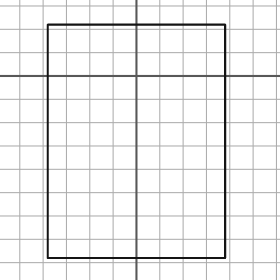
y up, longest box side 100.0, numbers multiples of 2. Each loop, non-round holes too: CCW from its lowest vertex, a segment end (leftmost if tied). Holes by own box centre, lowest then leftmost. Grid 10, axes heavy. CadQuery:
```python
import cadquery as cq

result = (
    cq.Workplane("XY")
    .moveTo(-38.0, -78.0)
    .lineTo(38.0, -78.0)
    .lineTo(38.0, 22.0)
    .lineTo(-38.0, 22.0)
    .close()
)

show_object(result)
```